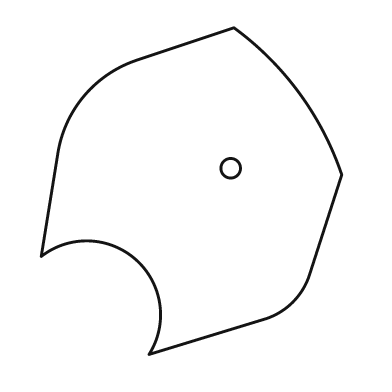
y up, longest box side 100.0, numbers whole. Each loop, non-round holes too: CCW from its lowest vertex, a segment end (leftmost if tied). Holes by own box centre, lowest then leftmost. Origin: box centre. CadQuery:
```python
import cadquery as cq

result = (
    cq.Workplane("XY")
    .moveTo(-13.0, -50.0)
    .lineTo(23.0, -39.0)
    .threePointArc((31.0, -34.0), (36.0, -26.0))
    .lineTo(46.0, 5.0)
    .threePointArc((33.0, 30.0), (13.0, 50.0))
    .lineTo(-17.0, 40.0)
    .threePointArc((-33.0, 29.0), (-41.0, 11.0))
    .lineTo(-46.0, -20.0)
    .threePointArc((-17.0, -21.0), (-13.0, -50.0))
    .close()
    .moveTo(12.0, 7.0)
    .circle(3.0)
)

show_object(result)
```